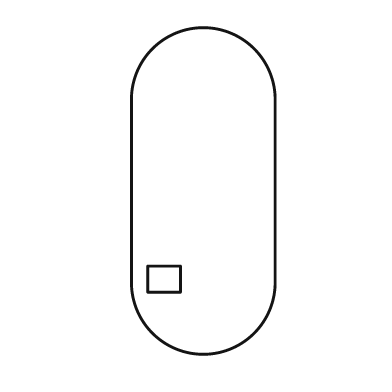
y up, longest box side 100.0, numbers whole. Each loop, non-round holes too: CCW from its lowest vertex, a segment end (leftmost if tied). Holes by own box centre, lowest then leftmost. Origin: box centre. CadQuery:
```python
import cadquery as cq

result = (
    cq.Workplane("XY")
    .moveTo(-22.0, -28.0)
    .threePointArc((0.0, -50.0), (22.0, -28.0))
    .lineTo(22.0, 28.0)
    .threePointArc((0.0, 50.0), (-22.0, 28.0))
    .close()
    .moveTo(-17.0, -31.0)
    .lineTo(-7.0, -31.0)
    .lineTo(-7.0, -23.0)
    .lineTo(-17.0, -23.0)
    .close()
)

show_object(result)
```